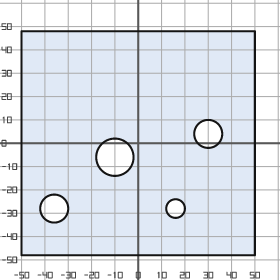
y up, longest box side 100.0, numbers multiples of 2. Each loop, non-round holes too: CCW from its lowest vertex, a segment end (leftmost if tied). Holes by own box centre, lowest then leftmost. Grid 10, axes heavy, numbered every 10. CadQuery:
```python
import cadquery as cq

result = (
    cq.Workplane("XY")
    .moveTo(-50.0, -48.0)
    .lineTo(50.0, -48.0)
    .lineTo(50.0, 48.0)
    .lineTo(-50.0, 48.0)
    .close()
    .moveTo(-36.0, -28.0)
    .circle(6.0)
    .moveTo(16.0, -28.0)
    .circle(4.0)
    .moveTo(-10.0, -6.0)
    .circle(8.0)
    .moveTo(30.0, 4.0)
    .circle(6.0)
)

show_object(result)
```